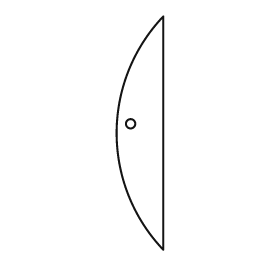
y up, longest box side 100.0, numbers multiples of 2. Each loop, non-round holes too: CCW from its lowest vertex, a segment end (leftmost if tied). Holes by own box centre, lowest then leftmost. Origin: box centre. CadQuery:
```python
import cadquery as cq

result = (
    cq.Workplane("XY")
    .moveTo(10.0, -50.0)
    .lineTo(10.0, 50.0)
    .threePointArc((-10.0, 0.0), (10.0, -50.0))
    .close()
    .moveTo(-4.0, 4.0)
    .circle(2.0)
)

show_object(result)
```